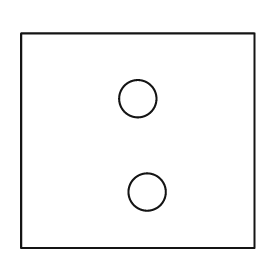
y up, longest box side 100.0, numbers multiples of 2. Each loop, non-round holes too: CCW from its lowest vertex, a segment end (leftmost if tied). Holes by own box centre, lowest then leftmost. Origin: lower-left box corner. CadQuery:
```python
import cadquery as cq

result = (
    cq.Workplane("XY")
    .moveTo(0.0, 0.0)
    .lineTo(100.0, 0.0)
    .lineTo(100.0, 92.0)
    .lineTo(0.0, 92.0)
    .close()
    .moveTo(54.0, 24.0)
    .circle(8.0)
    .moveTo(50.0, 64.0)
    .circle(8.0)
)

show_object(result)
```